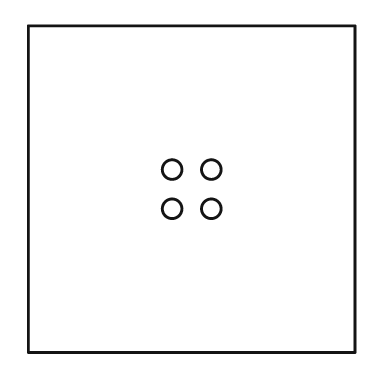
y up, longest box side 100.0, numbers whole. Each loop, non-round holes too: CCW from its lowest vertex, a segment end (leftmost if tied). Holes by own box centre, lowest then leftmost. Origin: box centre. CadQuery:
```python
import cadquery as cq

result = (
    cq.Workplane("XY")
    .moveTo(-50.0, -50.0)
    .lineTo(50.0, -50.0)
    .lineTo(50.0, 50.0)
    .lineTo(-50.0, 50.0)
    .close()
    .moveTo(-6.0, -6.0)
    .circle(3.0)
    .moveTo(6.0, -6.0)
    .circle(3.0)
    .moveTo(-6.0, 6.0)
    .circle(3.0)
    .moveTo(6.0, 6.0)
    .circle(3.0)
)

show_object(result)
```